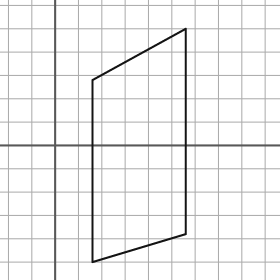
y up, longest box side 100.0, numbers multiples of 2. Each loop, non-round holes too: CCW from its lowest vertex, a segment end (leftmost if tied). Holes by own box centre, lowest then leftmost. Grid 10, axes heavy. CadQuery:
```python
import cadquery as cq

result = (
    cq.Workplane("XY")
    .moveTo(16.0, -50.0)
    .lineTo(56.0, -38.0)
    .lineTo(56.0, 50.0)
    .lineTo(16.0, 28.0)
    .close()
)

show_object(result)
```